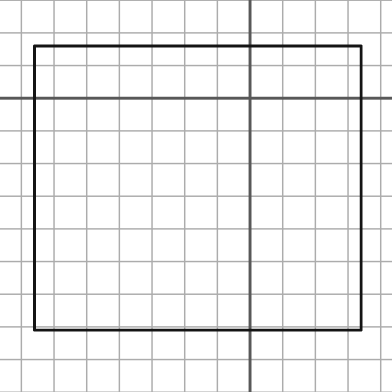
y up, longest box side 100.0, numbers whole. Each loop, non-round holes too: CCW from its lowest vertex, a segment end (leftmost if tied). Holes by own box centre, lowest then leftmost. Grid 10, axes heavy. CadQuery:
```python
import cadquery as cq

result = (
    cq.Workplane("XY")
    .moveTo(-66.0, -71.0)
    .lineTo(34.0, -71.0)
    .lineTo(34.0, 16.0)
    .lineTo(-66.0, 16.0)
    .close()
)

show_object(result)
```